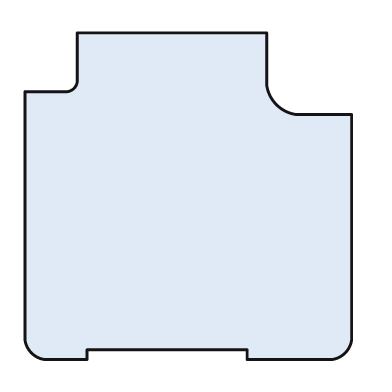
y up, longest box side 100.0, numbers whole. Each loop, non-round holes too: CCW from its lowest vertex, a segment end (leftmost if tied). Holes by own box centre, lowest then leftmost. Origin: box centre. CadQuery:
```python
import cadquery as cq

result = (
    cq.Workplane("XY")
    .moveTo(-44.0, -50.0)
    .lineTo(-31.0, -50.0)
    .lineTo(-31.0, -47.0)
    .lineTo(18.0, -47.0)
    .lineTo(18.0, -50.0)
    .lineTo(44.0, -50.0)
    .threePointArc((48.0, -48.0), (50.0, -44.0))
    .lineTo(50.0, 25.0)
    .lineTo(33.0, 25.0)
    .threePointArc((27.0, 28.0), (24.0, 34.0))
    .lineTo(24.0, 50.0)
    .lineTo(-34.0, 50.0)
    .lineTo(-34.0, 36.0)
    .threePointArc((-35.0, 33.0), (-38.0, 32.0))
    .lineTo(-50.0, 32.0)
    .lineTo(-50.0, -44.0)
    .threePointArc((-48.0, -48.0), (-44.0, -50.0))
    .close()
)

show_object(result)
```